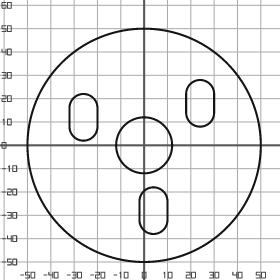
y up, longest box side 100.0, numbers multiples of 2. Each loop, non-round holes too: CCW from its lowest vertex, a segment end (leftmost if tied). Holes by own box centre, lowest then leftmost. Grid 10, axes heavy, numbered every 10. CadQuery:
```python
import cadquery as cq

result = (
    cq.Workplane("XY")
    .moveTo(0.0, 0.0)
    .circle(50.0)
    .moveTo(-2.0, -32.0)
    .threePointArc((4.0, -38.0), (10.0, -32.0))
    .lineTo(10.0, -24.0)
    .threePointArc((4.0, -18.0), (-2.0, -24.0))
    .close()
    .moveTo(0.0, 0.0)
    .circle(12.0)
    .moveTo(-32.0, 8.0)
    .threePointArc((-26.0, 2.0), (-20.0, 8.0))
    .lineTo(-20.0, 16.0)
    .threePointArc((-26.0, 22.0), (-32.0, 16.0))
    .close()
    .moveTo(18.0, 14.0)
    .threePointArc((24.0, 8.0), (30.0, 14.0))
    .lineTo(30.0, 22.0)
    .threePointArc((24.0, 28.0), (18.0, 22.0))
    .close()
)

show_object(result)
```